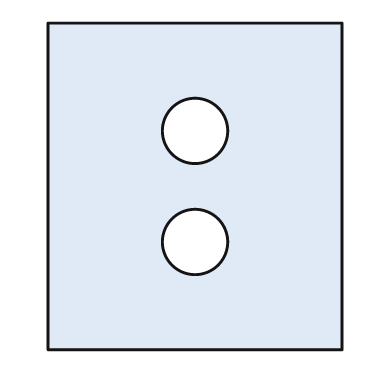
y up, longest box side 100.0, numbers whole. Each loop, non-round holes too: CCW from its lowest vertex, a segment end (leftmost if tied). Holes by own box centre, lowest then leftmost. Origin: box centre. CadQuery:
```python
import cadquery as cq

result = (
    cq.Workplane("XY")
    .moveTo(-45.0, -50.0)
    .lineTo(45.0, -50.0)
    .lineTo(45.0, 50.0)
    .lineTo(-45.0, 50.0)
    .close()
    .moveTo(0.0, -17.0)
    .circle(10.0)
    .moveTo(0.0, 17.0)
    .circle(10.0)
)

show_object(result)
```